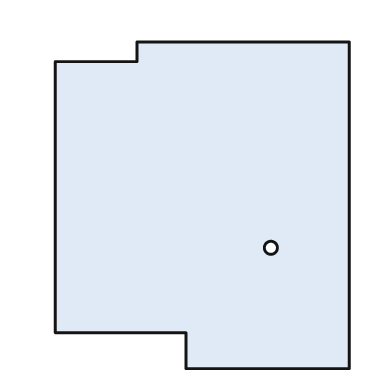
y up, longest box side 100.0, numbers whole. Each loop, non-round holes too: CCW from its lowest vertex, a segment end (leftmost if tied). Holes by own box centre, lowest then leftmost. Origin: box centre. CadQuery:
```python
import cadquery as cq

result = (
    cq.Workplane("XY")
    .moveTo(-5.0, -50.0)
    .lineTo(45.0, -50.0)
    .lineTo(45.0, 50.0)
    .lineTo(-20.0, 50.0)
    .lineTo(-20.0, 44.0)
    .lineTo(-45.0, 44.0)
    .lineTo(-45.0, -39.0)
    .lineTo(-5.0, -39.0)
    .close()
    .moveTo(21.0, -13.0)
    .circle(2.0)
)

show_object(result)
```